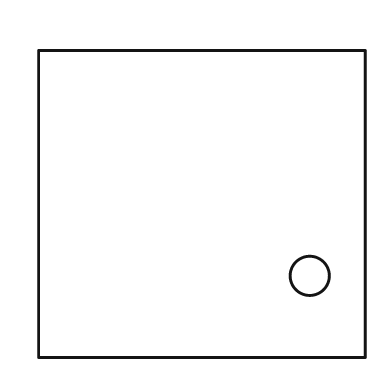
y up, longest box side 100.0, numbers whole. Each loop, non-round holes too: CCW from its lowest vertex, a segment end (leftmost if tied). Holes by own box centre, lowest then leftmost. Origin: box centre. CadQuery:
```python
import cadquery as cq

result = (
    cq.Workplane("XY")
    .moveTo(-50.0, -47.0)
    .lineTo(50.0, -47.0)
    .lineTo(50.0, 47.0)
    .lineTo(-50.0, 47.0)
    .close()
    .moveTo(33.0, -22.0)
    .circle(6.0)
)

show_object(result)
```